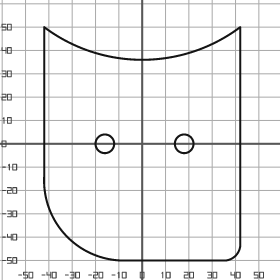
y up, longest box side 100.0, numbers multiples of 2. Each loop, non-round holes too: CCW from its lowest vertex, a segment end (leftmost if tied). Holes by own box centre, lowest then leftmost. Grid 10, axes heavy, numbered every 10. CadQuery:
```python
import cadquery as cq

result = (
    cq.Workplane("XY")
    .moveTo(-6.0, -50.0)
    .lineTo(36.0, -50.0)
    .threePointArc((40.0, -48.0), (42.0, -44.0))
    .lineTo(42.0, 50.0)
    .threePointArc((0.0, 36.0), (-42.0, 50.0))
    .lineTo(-42.0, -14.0)
    .threePointArc((-32.0, -40.0), (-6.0, -50.0))
    .close()
    .moveTo(-16.0, 0.0)
    .circle(4.0)
    .moveTo(18.0, 0.0)
    .circle(4.0)
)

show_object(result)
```